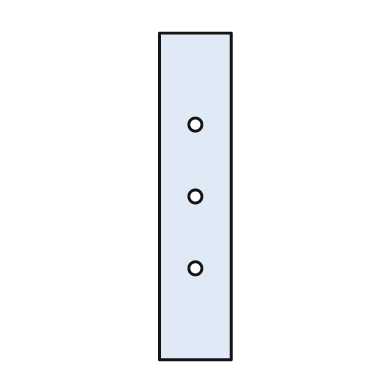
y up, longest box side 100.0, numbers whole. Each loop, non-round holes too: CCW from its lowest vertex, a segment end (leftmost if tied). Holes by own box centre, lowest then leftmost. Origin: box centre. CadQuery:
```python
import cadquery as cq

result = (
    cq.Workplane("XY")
    .moveTo(-11.0, -50.0)
    .lineTo(11.0, -50.0)
    .lineTo(11.0, 50.0)
    .lineTo(-11.0, 50.0)
    .close()
    .moveTo(0.0, -22.0)
    .circle(2.0)
    .moveTo(0.0, 0.0)
    .circle(2.0)
    .moveTo(0.0, 22.0)
    .circle(2.0)
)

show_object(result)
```